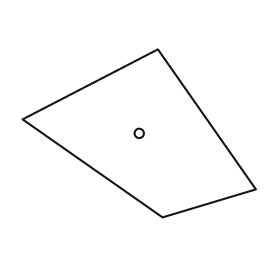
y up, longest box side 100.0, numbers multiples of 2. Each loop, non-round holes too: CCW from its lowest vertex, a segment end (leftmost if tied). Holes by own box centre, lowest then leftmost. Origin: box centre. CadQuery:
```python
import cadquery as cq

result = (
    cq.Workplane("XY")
    .moveTo(10.0, -36.0)
    .lineTo(50.0, -24.0)
    .lineTo(8.0, 36.0)
    .lineTo(-50.0, 6.0)
    .close()
    .moveTo(0.0, 0.0)
    .circle(2.0)
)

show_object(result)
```